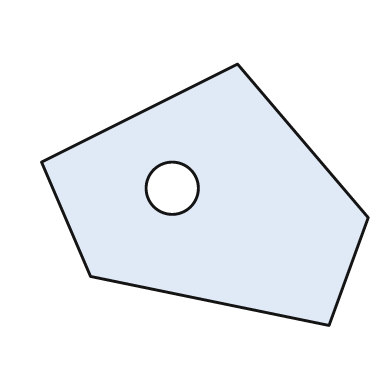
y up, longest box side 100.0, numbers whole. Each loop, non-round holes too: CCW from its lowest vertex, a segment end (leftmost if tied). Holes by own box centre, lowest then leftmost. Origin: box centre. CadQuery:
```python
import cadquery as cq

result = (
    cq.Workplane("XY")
    .moveTo(38.0, -40.0)
    .lineTo(50.0, -7.0)
    .lineTo(10.0, 40.0)
    .lineTo(-50.0, 10.0)
    .lineTo(-35.0, -25.0)
    .close()
    .moveTo(-10.0, 2.0)
    .circle(8.0)
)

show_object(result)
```